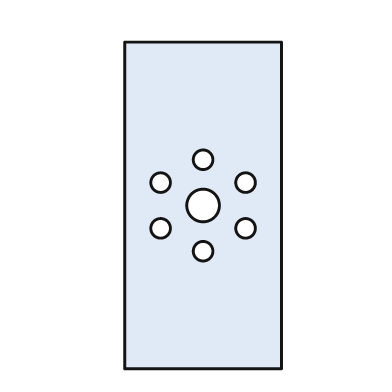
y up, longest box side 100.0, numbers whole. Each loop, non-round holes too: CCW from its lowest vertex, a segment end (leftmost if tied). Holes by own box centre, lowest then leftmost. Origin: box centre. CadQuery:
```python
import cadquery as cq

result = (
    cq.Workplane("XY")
    .moveTo(-24.0, -50.0)
    .lineTo(24.0, -50.0)
    .lineTo(24.0, 50.0)
    .lineTo(-24.0, 50.0)
    .close()
    .moveTo(0.0, -14.0)
    .circle(3.0)
    .moveTo(-13.0, -7.0)
    .circle(3.0)
    .moveTo(13.0, -7.0)
    .circle(3.0)
    .moveTo(0.0, 0.0)
    .circle(5.0)
    .moveTo(-13.0, 7.0)
    .circle(3.0)
    .moveTo(13.0, 7.0)
    .circle(3.0)
    .moveTo(0.0, 14.0)
    .circle(3.0)
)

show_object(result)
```